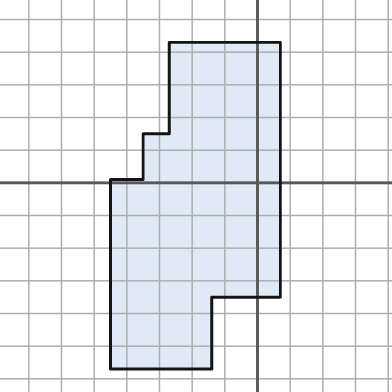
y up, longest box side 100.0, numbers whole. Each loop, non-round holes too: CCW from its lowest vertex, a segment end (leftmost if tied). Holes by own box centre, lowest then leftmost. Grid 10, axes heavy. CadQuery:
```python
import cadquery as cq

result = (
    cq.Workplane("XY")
    .moveTo(-45.0, -57.0)
    .lineTo(-14.0, -57.0)
    .lineTo(-14.0, -35.0)
    .lineTo(7.0, -35.0)
    .lineTo(7.0, 43.0)
    .lineTo(-27.0, 43.0)
    .lineTo(-27.0, 15.0)
    .lineTo(-35.0, 15.0)
    .lineTo(-35.0, 1.0)
    .lineTo(-45.0, 1.0)
    .close()
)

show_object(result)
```